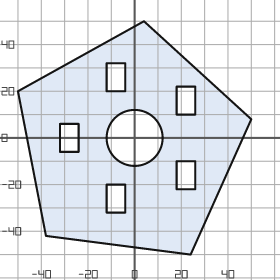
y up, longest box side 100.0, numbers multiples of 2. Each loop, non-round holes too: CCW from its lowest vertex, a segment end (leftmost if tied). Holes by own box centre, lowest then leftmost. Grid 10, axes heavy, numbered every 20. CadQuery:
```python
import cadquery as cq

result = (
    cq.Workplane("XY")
    .moveTo(24.0, -50.0)
    .lineTo(50.0, 8.0)
    .lineTo(4.0, 50.0)
    .lineTo(-50.0, 20.0)
    .lineTo(-38.0, -42.0)
    .close()
    .moveTo(-12.0, -32.0)
    .lineTo(-4.0, -32.0)
    .lineTo(-4.0, -20.0)
    .lineTo(-12.0, -20.0)
    .close()
    .moveTo(18.0, -22.0)
    .lineTo(26.0, -22.0)
    .lineTo(26.0, -10.0)
    .lineTo(18.0, -10.0)
    .close()
    .moveTo(-32.0, -6.0)
    .lineTo(-24.0, -6.0)
    .lineTo(-24.0, 6.0)
    .lineTo(-32.0, 6.0)
    .close()
    .moveTo(0.0, 0.0)
    .circle(12.0)
    .moveTo(18.0, 10.0)
    .lineTo(26.0, 10.0)
    .lineTo(26.0, 22.0)
    .lineTo(18.0, 22.0)
    .close()
    .moveTo(-12.0, 20.0)
    .lineTo(-4.0, 20.0)
    .lineTo(-4.0, 32.0)
    .lineTo(-12.0, 32.0)
    .close()
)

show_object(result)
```